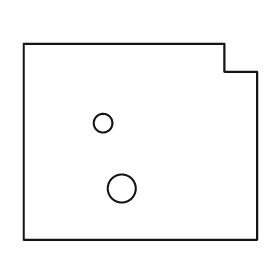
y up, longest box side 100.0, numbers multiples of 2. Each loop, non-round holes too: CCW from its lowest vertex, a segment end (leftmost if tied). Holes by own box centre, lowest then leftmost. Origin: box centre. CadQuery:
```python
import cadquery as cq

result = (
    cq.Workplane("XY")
    .moveTo(-50.0, -42.0)
    .lineTo(50.0, -42.0)
    .lineTo(50.0, 30.0)
    .lineTo(36.0, 30.0)
    .lineTo(36.0, 42.0)
    .lineTo(-50.0, 42.0)
    .close()
    .moveTo(-8.0, -20.0)
    .circle(6.0)
    .moveTo(-16.0, 8.0)
    .circle(4.0)
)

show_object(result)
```